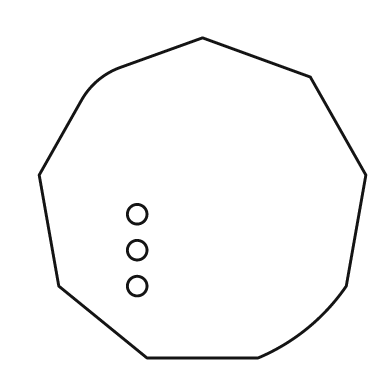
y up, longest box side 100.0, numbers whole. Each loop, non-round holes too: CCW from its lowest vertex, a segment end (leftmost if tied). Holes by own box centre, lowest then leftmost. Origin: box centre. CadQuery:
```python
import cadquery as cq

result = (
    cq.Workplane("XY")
    .moveTo(-17.0, -49.0)
    .lineTo(17.0, -49.0)
    .threePointArc((32.0, -40.0), (44.0, -27.0))
    .lineTo(50.0, 7.0)
    .lineTo(33.0, 37.0)
    .lineTo(0.0, 49.0)
    .lineTo(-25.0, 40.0)
    .threePointArc((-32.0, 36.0), (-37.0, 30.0))
    .lineTo(-50.0, 7.0)
    .lineTo(-44.0, -27.0)
    .close()
    .moveTo(-20.0, -27.0)
    .circle(3.0)
    .moveTo(-20.0, -16.0)
    .circle(3.0)
    .moveTo(-20.0, -5.0)
    .circle(3.0)
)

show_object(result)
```